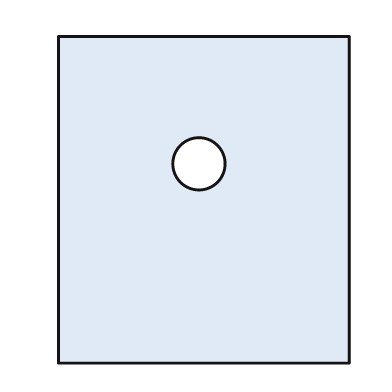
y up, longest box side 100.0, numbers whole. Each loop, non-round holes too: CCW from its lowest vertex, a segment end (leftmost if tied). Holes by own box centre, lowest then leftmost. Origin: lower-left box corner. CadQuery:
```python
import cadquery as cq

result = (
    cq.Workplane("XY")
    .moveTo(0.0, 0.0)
    .lineTo(89.0, 0.0)
    .lineTo(89.0, 100.0)
    .lineTo(0.0, 100.0)
    .close()
    .moveTo(43.0, 61.0)
    .circle(8.0)
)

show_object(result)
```